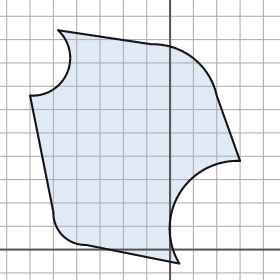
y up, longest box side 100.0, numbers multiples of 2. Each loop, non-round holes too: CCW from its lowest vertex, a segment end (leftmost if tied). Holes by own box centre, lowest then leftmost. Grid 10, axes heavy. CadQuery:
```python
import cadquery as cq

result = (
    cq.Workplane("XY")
    .moveTo(4.0, -6.0)
    .threePointArc((4.0, 24.0), (30.0, 38.0))
    .lineTo(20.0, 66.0)
    .threePointArc((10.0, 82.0), (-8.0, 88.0))
    .lineTo(-48.0, 94.0)
    .threePointArc((-44.0, 76.0), (-60.0, 66.0))
    .lineTo(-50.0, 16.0)
    .threePointArc((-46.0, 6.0), (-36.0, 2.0))
    .close()
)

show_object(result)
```